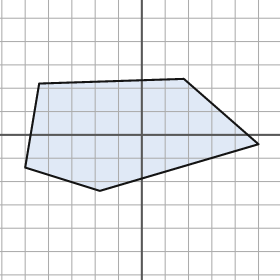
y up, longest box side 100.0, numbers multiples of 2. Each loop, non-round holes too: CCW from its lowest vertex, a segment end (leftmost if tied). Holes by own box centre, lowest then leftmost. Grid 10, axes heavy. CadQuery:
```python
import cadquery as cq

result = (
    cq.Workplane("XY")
    .moveTo(-18.0, -24.0)
    .lineTo(50.0, -4.0)
    .lineTo(18.0, 24.0)
    .lineTo(-44.0, 22.0)
    .lineTo(-50.0, -14.0)
    .close()
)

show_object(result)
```